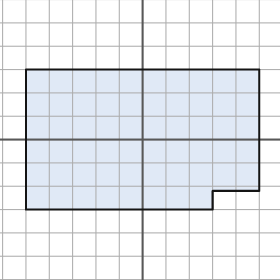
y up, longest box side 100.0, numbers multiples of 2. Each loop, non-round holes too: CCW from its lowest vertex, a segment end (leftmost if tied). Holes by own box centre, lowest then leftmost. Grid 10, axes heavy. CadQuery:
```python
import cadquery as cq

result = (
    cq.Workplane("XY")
    .moveTo(-50.0, -30.0)
    .lineTo(30.0, -30.0)
    .lineTo(30.0, -22.0)
    .lineTo(50.0, -22.0)
    .lineTo(50.0, 30.0)
    .lineTo(-50.0, 30.0)
    .close()
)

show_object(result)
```